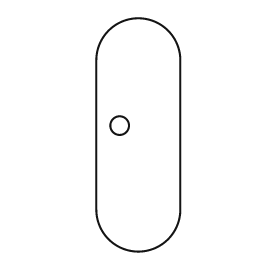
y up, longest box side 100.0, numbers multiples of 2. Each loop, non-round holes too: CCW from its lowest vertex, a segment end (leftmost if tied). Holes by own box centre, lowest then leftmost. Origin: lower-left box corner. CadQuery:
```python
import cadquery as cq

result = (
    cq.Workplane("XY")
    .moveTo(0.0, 18.0)
    .threePointArc((18.0, 0.0), (36.0, 18.0))
    .lineTo(36.0, 82.0)
    .threePointArc((18.0, 100.0), (0.0, 82.0))
    .close()
    .moveTo(10.0, 54.0)
    .circle(4.0)
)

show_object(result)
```